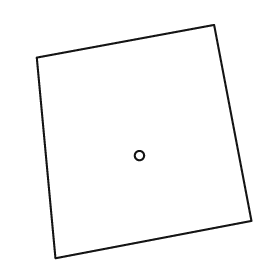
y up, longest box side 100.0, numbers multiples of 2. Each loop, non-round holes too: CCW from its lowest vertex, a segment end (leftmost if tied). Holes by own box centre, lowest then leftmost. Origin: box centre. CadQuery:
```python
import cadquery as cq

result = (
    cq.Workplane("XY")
    .moveTo(-38.0, -50.0)
    .lineTo(46.0, -34.0)
    .lineTo(30.0, 50.0)
    .lineTo(-46.0, 36.0)
    .close()
    .moveTo(-2.0, -6.0)
    .circle(2.0)
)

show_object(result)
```